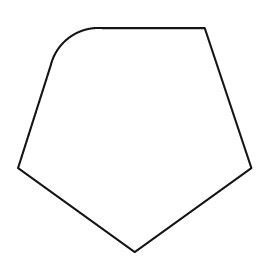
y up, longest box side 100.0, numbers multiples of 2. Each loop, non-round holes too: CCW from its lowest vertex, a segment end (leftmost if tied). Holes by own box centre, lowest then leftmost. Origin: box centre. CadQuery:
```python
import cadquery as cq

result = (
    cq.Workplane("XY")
    .moveTo(0.0, -48.0)
    .lineTo(50.0, -12.0)
    .lineTo(30.0, 48.0)
    .lineTo(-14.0, 48.0)
    .threePointArc((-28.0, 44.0), (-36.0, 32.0))
    .lineTo(-50.0, -12.0)
    .close()
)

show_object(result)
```